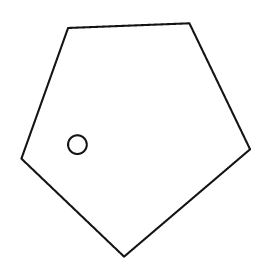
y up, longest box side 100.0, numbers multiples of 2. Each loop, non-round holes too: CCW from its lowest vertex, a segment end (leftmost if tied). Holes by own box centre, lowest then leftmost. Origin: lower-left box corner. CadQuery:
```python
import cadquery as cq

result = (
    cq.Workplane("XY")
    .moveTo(44.0, 0.0)
    .lineTo(98.0, 46.0)
    .lineTo(72.0, 100.0)
    .lineTo(20.0, 98.0)
    .lineTo(0.0, 42.0)
    .close()
    .moveTo(24.0, 48.0)
    .circle(4.0)
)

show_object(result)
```